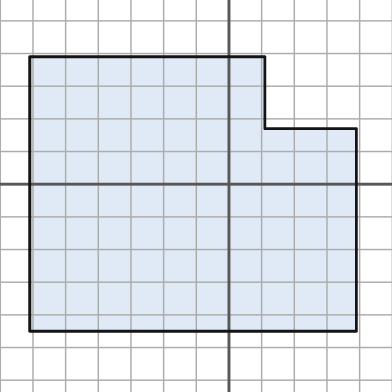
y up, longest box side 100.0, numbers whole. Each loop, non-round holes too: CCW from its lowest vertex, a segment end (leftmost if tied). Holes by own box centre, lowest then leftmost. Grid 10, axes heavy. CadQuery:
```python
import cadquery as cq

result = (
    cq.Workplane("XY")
    .moveTo(-61.0, -45.0)
    .lineTo(39.0, -45.0)
    .lineTo(39.0, 17.0)
    .lineTo(11.0, 17.0)
    .lineTo(11.0, 39.0)
    .lineTo(-61.0, 39.0)
    .close()
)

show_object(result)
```